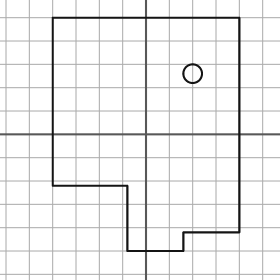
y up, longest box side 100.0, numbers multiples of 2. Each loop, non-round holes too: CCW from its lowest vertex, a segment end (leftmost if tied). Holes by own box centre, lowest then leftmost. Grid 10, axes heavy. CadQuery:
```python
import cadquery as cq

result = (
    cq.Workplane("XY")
    .moveTo(-8.0, -50.0)
    .lineTo(16.0, -50.0)
    .lineTo(16.0, -42.0)
    .lineTo(40.0, -42.0)
    .lineTo(40.0, 50.0)
    .lineTo(-40.0, 50.0)
    .lineTo(-40.0, -22.0)
    .lineTo(-8.0, -22.0)
    .close()
    .moveTo(20.0, 26.0)
    .circle(4.0)
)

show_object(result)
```